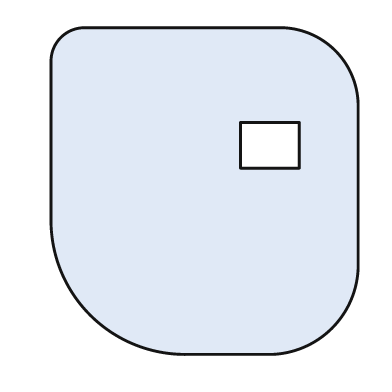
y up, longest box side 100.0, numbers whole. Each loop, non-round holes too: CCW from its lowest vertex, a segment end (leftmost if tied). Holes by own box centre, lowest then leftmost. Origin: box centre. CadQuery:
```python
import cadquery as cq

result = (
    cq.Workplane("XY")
    .moveTo(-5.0, -50.0)
    .lineTo(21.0, -50.0)
    .threePointArc((39.0, -42.0), (47.0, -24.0))
    .lineTo(47.0, 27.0)
    .threePointArc((40.0, 43.0), (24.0, 50.0))
    .lineTo(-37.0, 50.0)
    .threePointArc((-44.0, 47.0), (-47.0, 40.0))
    .lineTo(-47.0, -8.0)
    .threePointArc((-35.0, -38.0), (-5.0, -50.0))
    .close()
    .moveTo(11.0, 7.0)
    .lineTo(29.0, 7.0)
    .lineTo(29.0, 21.0)
    .lineTo(11.0, 21.0)
    .close()
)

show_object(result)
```